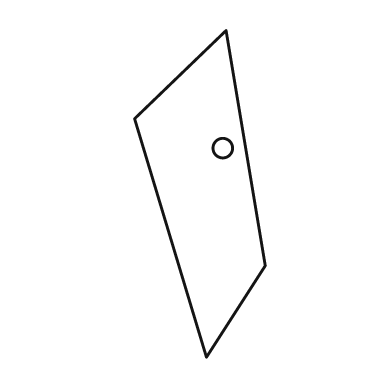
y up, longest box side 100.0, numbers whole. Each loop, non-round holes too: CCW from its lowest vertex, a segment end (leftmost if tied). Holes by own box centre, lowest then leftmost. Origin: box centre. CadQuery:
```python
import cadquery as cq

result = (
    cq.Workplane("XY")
    .moveTo(2.0, -50.0)
    .lineTo(20.0, -22.0)
    .lineTo(8.0, 50.0)
    .lineTo(-20.0, 23.0)
    .close()
    .moveTo(7.0, 14.0)
    .circle(3.0)
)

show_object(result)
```